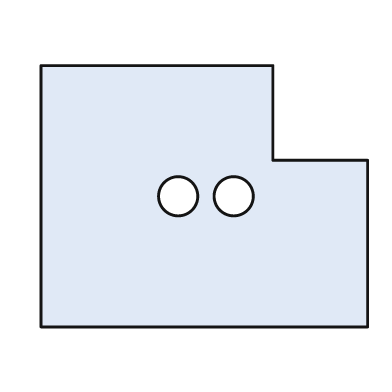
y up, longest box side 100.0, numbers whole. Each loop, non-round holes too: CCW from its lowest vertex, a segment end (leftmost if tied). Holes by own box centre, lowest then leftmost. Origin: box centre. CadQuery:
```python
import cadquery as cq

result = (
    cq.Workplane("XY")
    .moveTo(-50.0, -40.0)
    .lineTo(50.0, -40.0)
    .lineTo(50.0, 11.0)
    .lineTo(21.0, 11.0)
    .lineTo(21.0, 40.0)
    .lineTo(-50.0, 40.0)
    .close()
    .moveTo(-8.0, 0.0)
    .circle(6.0)
    .moveTo(9.0, 0.0)
    .circle(6.0)
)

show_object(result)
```